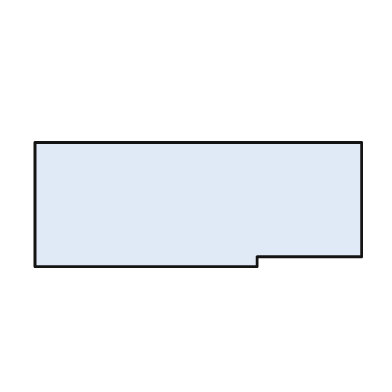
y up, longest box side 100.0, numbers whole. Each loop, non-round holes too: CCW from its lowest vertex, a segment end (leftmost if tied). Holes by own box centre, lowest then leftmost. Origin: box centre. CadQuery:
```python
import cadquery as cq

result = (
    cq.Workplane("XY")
    .moveTo(-50.0, -19.0)
    .lineTo(18.0, -19.0)
    .lineTo(18.0, -16.0)
    .lineTo(50.0, -16.0)
    .lineTo(50.0, 19.0)
    .lineTo(-50.0, 19.0)
    .close()
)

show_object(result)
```